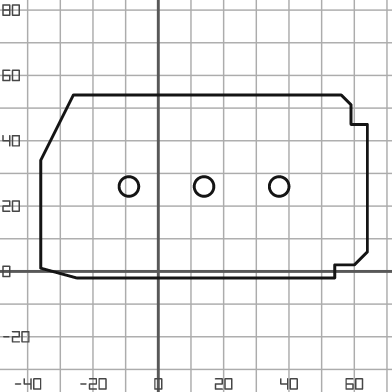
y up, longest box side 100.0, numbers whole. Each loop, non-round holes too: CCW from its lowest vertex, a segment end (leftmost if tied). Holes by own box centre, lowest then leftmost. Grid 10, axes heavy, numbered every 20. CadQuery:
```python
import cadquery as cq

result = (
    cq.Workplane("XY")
    .moveTo(-25.0, -2.0)
    .lineTo(54.0, -2.0)
    .lineTo(54.0, 2.0)
    .lineTo(60.0, 2.0)
    .lineTo(64.0, 6.0)
    .lineTo(64.0, 45.0)
    .lineTo(59.0, 45.0)
    .lineTo(59.0, 51.0)
    .lineTo(56.0, 54.0)
    .lineTo(-26.0, 54.0)
    .lineTo(-36.0, 34.0)
    .lineTo(-36.0, 1.0)
    .close()
    .moveTo(-9.0, 26.0)
    .circle(3.0)
    .moveTo(14.0, 26.0)
    .circle(3.0)
    .moveTo(37.0, 26.0)
    .circle(3.0)
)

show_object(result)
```